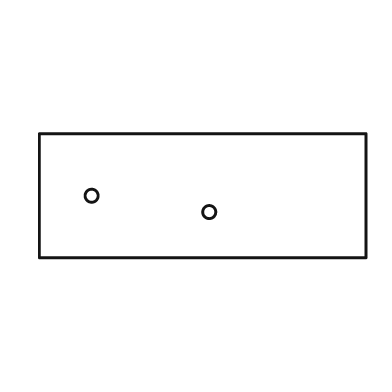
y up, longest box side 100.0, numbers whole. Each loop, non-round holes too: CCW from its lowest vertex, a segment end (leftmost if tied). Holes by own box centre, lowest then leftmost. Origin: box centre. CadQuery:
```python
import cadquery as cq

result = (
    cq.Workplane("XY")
    .moveTo(-50.0, -19.0)
    .lineTo(50.0, -19.0)
    .lineTo(50.0, 19.0)
    .lineTo(-50.0, 19.0)
    .close()
    .moveTo(2.0, -5.0)
    .circle(2.0)
    .moveTo(-34.0, 0.0)
    .circle(2.0)
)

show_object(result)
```